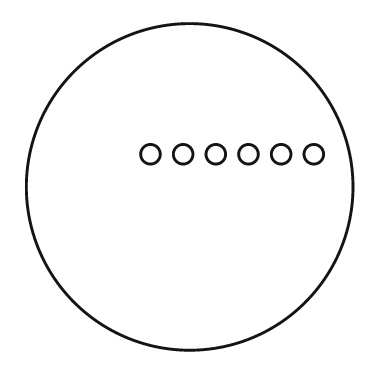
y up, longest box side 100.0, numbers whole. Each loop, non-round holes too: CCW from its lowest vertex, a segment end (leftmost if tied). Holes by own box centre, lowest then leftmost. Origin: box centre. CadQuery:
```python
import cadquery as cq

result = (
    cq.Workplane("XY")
    .moveTo(0.0, 0.0)
    .circle(50.0)
    .moveTo(-12.0, 10.0)
    .circle(3.0)
    .moveTo(-2.0, 10.0)
    .circle(3.0)
    .moveTo(8.0, 10.0)
    .circle(3.0)
    .moveTo(18.0, 10.0)
    .circle(3.0)
    .moveTo(28.0, 10.0)
    .circle(3.0)
    .moveTo(38.0, 10.0)
    .circle(3.0)
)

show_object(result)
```